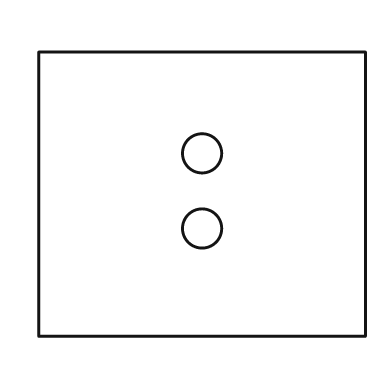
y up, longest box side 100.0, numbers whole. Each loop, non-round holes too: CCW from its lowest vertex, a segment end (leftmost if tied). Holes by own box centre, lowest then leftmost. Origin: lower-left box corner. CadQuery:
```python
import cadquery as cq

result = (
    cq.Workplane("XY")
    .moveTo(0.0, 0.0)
    .lineTo(100.0, 0.0)
    .lineTo(100.0, 87.0)
    .lineTo(0.0, 87.0)
    .close()
    .moveTo(50.0, 33.0)
    .circle(6.0)
    .moveTo(50.0, 56.0)
    .circle(6.0)
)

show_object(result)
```